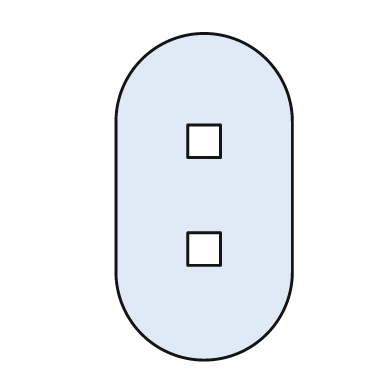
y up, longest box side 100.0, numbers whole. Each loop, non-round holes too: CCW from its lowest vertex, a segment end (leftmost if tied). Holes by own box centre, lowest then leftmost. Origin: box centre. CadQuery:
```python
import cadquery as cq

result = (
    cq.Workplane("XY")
    .moveTo(-27.0, -23.0)
    .threePointArc((0.0, -50.0), (27.0, -23.0))
    .lineTo(27.0, 23.0)
    .threePointArc((0.0, 50.0), (-27.0, 23.0))
    .close()
    .moveTo(-5.0, -21.0)
    .lineTo(5.0, -21.0)
    .lineTo(5.0, -11.0)
    .lineTo(-5.0, -11.0)
    .close()
    .moveTo(-5.0, 12.0)
    .lineTo(5.0, 12.0)
    .lineTo(5.0, 22.0)
    .lineTo(-5.0, 22.0)
    .close()
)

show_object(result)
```